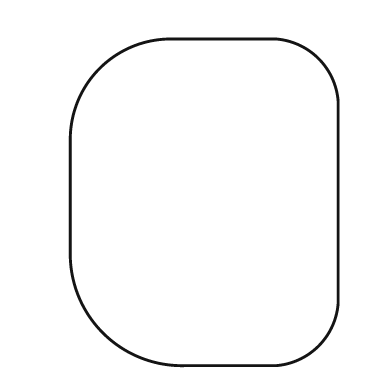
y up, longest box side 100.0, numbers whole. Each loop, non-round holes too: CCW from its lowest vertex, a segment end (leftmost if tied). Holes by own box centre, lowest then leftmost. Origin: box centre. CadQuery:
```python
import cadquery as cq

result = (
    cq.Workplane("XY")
    .moveTo(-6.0, -50.0)
    .lineTo(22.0, -50.0)
    .threePointArc((35.0, -44.0), (41.0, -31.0))
    .lineTo(41.0, 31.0)
    .threePointArc((35.0, 44.0), (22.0, 50.0))
    .lineTo(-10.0, 50.0)
    .threePointArc((-32.0, 41.0), (-41.0, 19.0))
    .lineTo(-41.0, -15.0)
    .threePointArc((-31.0, -40.0), (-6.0, -50.0))
    .close()
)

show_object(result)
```